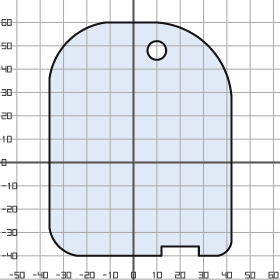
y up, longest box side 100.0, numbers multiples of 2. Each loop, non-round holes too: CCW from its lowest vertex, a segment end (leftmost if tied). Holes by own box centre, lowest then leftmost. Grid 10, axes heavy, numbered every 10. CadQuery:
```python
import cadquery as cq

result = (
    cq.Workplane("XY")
    .moveTo(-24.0, -40.0)
    .lineTo(12.0, -40.0)
    .lineTo(12.0, -36.0)
    .lineTo(28.0, -36.0)
    .lineTo(28.0, -40.0)
    .lineTo(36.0, -40.0)
    .threePointArc((40.0, -38.0), (42.0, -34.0))
    .lineTo(42.0, 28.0)
    .threePointArc((32.0, 50.0), (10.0, 60.0))
    .lineTo(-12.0, 60.0)
    .threePointArc((-28.0, 52.0), (-36.0, 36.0))
    .lineTo(-36.0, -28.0)
    .threePointArc((-32.0, -36.0), (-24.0, -40.0))
    .close()
    .moveTo(10.0, 48.0)
    .circle(4.0)
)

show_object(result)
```